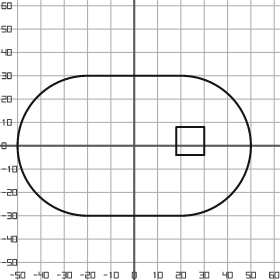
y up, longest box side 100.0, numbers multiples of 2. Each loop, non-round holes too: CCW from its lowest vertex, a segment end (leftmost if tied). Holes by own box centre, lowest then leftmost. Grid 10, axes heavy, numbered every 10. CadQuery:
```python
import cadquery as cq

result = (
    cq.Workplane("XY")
    .moveTo(-20.0, -30.0)
    .lineTo(20.0, -30.0)
    .threePointArc((50.0, 0.0), (20.0, 30.0))
    .lineTo(-20.0, 30.0)
    .threePointArc((-50.0, 0.0), (-20.0, -30.0))
    .close()
    .moveTo(18.0, -4.0)
    .lineTo(30.0, -4.0)
    .lineTo(30.0, 8.0)
    .lineTo(18.0, 8.0)
    .close()
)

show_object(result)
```